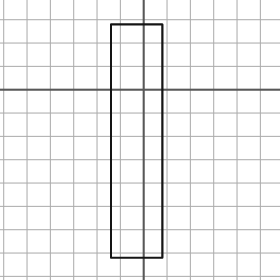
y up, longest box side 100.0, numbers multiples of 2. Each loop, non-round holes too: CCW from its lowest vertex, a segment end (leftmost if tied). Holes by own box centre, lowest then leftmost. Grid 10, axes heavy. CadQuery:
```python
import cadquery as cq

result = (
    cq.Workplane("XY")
    .moveTo(-14.0, -72.0)
    .lineTo(8.0, -72.0)
    .lineTo(8.0, 28.0)
    .lineTo(-14.0, 28.0)
    .close()
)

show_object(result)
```